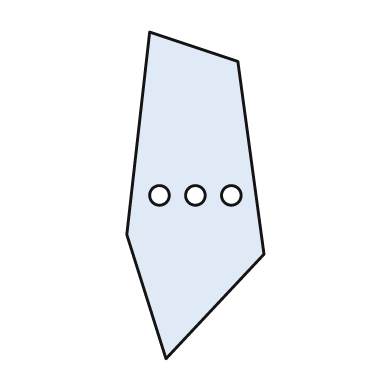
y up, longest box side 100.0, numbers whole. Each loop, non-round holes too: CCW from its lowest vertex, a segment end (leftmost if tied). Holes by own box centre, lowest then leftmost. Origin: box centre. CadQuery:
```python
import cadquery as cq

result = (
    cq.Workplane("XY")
    .moveTo(-9.0, -50.0)
    .lineTo(21.0, -18.0)
    .lineTo(13.0, 41.0)
    .lineTo(-14.0, 50.0)
    .lineTo(-21.0, -12.0)
    .close()
    .moveTo(-11.0, 0.0)
    .circle(3.0)
    .moveTo(0.0, 0.0)
    .circle(3.0)
    .moveTo(11.0, 0.0)
    .circle(3.0)
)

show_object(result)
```